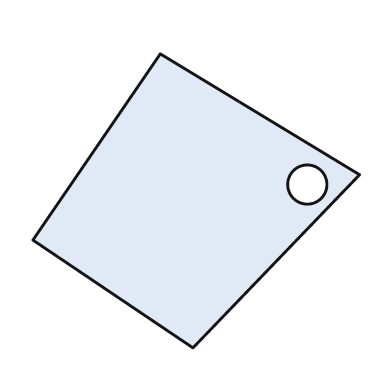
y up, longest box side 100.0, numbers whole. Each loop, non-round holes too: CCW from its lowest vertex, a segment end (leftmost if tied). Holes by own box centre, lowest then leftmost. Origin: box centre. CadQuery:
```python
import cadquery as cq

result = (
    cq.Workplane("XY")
    .moveTo(-1.0, -45.0)
    .lineTo(50.0, 8.0)
    .lineTo(-11.0, 45.0)
    .lineTo(-50.0, -12.0)
    .close()
    .moveTo(34.0, 5.0)
    .circle(6.0)
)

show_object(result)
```